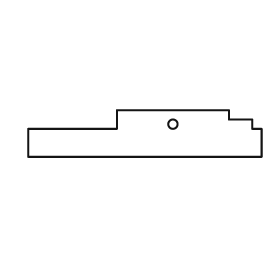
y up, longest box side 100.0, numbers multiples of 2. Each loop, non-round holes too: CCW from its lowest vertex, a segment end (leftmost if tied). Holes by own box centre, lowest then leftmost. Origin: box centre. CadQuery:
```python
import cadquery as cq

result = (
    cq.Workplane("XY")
    .moveTo(-50.0, -10.0)
    .lineTo(50.0, -10.0)
    .lineTo(50.0, 2.0)
    .lineTo(46.0, 2.0)
    .lineTo(46.0, 6.0)
    .lineTo(36.0, 6.0)
    .lineTo(36.0, 10.0)
    .lineTo(-12.0, 10.0)
    .lineTo(-12.0, 2.0)
    .lineTo(-50.0, 2.0)
    .close()
    .moveTo(12.0, 4.0)
    .circle(2.0)
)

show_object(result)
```